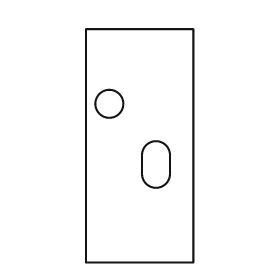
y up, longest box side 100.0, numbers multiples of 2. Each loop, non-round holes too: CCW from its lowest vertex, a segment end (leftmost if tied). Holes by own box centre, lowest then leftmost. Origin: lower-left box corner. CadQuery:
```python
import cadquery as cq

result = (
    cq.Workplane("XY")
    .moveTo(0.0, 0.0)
    .lineTo(46.0, 0.0)
    .lineTo(46.0, 100.0)
    .lineTo(0.0, 100.0)
    .close()
    .moveTo(24.0, 38.0)
    .threePointArc((30.0, 32.0), (36.0, 38.0))
    .lineTo(36.0, 46.0)
    .threePointArc((30.0, 52.0), (24.0, 46.0))
    .close()
    .moveTo(10.0, 68.0)
    .circle(6.0)
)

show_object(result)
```